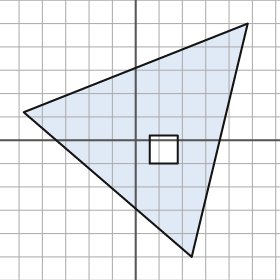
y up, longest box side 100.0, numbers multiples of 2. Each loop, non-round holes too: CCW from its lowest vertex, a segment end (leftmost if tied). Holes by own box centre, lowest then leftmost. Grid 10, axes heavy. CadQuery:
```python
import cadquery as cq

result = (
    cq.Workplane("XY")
    .moveTo(24.0, -50.0)
    .lineTo(48.0, 50.0)
    .lineTo(-48.0, 12.0)
    .close()
    .moveTo(6.0, -10.0)
    .lineTo(18.0, -10.0)
    .lineTo(18.0, 2.0)
    .lineTo(6.0, 2.0)
    .close()
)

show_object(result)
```